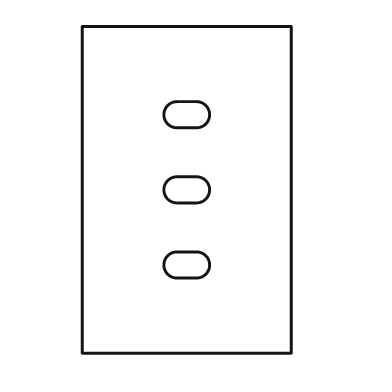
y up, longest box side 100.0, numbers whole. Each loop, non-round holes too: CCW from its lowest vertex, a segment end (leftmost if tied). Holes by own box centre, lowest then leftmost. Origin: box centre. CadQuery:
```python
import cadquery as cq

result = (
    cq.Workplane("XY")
    .moveTo(-32.0, -50.0)
    .lineTo(32.0, -50.0)
    .lineTo(32.0, 50.0)
    .lineTo(-32.0, 50.0)
    .close()
    .moveTo(-3.0, -27.0)
    .lineTo(3.0, -27.0)
    .threePointArc((7.0, -23.0), (3.0, -19.0))
    .lineTo(-3.0, -19.0)
    .threePointArc((-7.0, -23.0), (-3.0, -27.0))
    .close()
    .moveTo(-3.0, -4.0)
    .lineTo(3.0, -4.0)
    .threePointArc((7.0, 0.0), (3.0, 4.0))
    .lineTo(-3.0, 4.0)
    .threePointArc((-7.0, 0.0), (-3.0, -4.0))
    .close()
    .moveTo(-3.0, 19.0)
    .lineTo(3.0, 19.0)
    .threePointArc((7.0, 23.0), (3.0, 27.0))
    .lineTo(-3.0, 27.0)
    .threePointArc((-7.0, 23.0), (-3.0, 19.0))
    .close()
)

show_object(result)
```